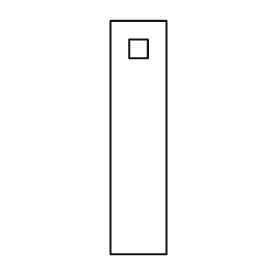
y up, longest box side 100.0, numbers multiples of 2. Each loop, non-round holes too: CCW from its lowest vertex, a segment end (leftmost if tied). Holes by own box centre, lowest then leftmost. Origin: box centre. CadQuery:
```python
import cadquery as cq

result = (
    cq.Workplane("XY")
    .moveTo(-12.0, -50.0)
    .lineTo(12.0, -50.0)
    .lineTo(12.0, 50.0)
    .lineTo(-12.0, 50.0)
    .close()
    .moveTo(-4.0, 34.0)
    .lineTo(4.0, 34.0)
    .lineTo(4.0, 42.0)
    .lineTo(-4.0, 42.0)
    .close()
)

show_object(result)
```